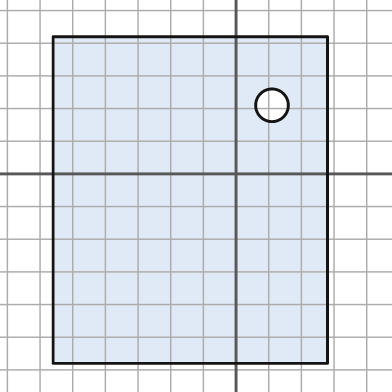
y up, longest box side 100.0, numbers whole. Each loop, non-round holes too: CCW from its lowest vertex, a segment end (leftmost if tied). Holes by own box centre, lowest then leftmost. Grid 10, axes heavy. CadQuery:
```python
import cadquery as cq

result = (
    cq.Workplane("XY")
    .moveTo(-56.0, -58.0)
    .lineTo(28.0, -58.0)
    .lineTo(28.0, 42.0)
    .lineTo(-56.0, 42.0)
    .close()
    .moveTo(11.0, 21.0)
    .circle(5.0)
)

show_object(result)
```